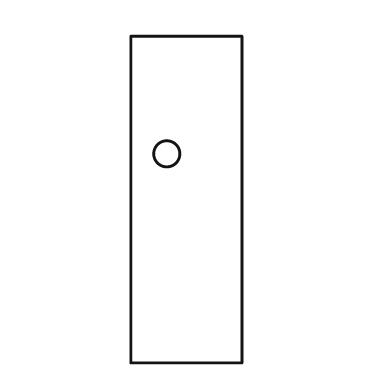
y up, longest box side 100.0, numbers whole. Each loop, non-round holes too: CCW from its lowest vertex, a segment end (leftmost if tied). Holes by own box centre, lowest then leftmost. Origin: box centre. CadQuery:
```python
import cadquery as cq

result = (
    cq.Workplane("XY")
    .moveTo(-17.0, -50.0)
    .lineTo(17.0, -50.0)
    .lineTo(17.0, 50.0)
    .lineTo(-17.0, 50.0)
    .close()
    .moveTo(-6.0, 14.0)
    .circle(4.0)
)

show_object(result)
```